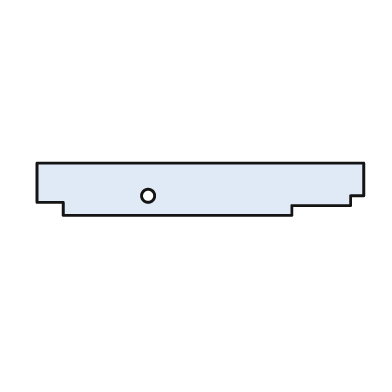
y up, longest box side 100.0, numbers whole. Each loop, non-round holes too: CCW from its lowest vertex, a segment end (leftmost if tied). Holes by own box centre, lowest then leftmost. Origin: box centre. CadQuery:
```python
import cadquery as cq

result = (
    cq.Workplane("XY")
    .moveTo(-42.0, -8.0)
    .lineTo(28.0, -8.0)
    .lineTo(28.0, -5.0)
    .lineTo(46.0, -5.0)
    .lineTo(46.0, -2.0)
    .lineTo(50.0, -2.0)
    .lineTo(50.0, 8.0)
    .lineTo(-50.0, 8.0)
    .lineTo(-50.0, -4.0)
    .lineTo(-42.0, -4.0)
    .close()
    .moveTo(-16.0, -2.0)
    .circle(2.0)
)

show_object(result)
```